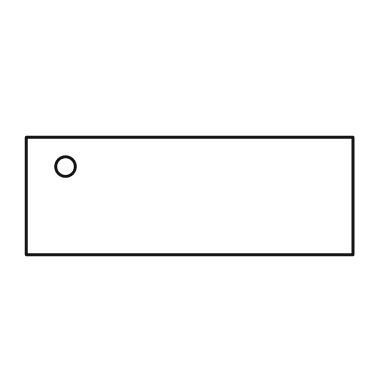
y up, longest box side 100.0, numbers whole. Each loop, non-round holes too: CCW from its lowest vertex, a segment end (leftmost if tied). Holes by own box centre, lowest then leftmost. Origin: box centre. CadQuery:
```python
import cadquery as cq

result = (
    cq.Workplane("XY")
    .moveTo(-50.0, -18.0)
    .lineTo(50.0, -18.0)
    .lineTo(50.0, 18.0)
    .lineTo(-50.0, 18.0)
    .close()
    .moveTo(-38.0, 9.0)
    .circle(3.0)
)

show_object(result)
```